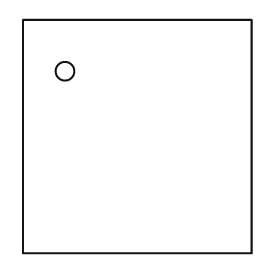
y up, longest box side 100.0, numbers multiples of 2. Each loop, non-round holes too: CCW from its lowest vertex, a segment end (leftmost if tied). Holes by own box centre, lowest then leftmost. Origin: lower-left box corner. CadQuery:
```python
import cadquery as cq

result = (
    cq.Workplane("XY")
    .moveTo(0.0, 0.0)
    .lineTo(98.0, 0.0)
    .lineTo(98.0, 100.0)
    .lineTo(0.0, 100.0)
    .close()
    .moveTo(18.0, 78.0)
    .circle(4.0)
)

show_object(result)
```